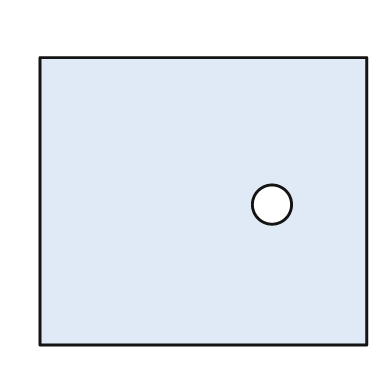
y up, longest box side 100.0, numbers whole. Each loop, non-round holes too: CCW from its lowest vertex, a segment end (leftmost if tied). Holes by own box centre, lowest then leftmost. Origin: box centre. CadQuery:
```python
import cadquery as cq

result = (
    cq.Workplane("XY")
    .moveTo(-50.0, -44.0)
    .lineTo(50.0, -44.0)
    .lineTo(50.0, 44.0)
    .lineTo(-50.0, 44.0)
    .close()
    .moveTo(21.0, -1.0)
    .circle(6.0)
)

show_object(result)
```